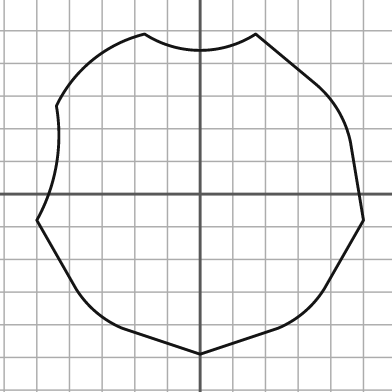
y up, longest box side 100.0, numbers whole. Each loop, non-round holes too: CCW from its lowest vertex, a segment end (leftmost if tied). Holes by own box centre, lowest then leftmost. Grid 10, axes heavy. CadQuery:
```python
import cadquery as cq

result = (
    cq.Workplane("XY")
    .moveTo(0.0, -49.0)
    .lineTo(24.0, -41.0)
    .threePointArc((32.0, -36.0), (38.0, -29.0))
    .lineTo(50.0, -8.0)
    .lineTo(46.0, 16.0)
    .threePointArc((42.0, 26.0), (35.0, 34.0))
    .lineTo(17.0, 49.0)
    .threePointArc((0.0, 44.0), (-17.0, 49.0))
    .threePointArc((-33.0, 41.0), (-44.0, 27.0))
    .threePointArc((-44.0, 9.0), (-50.0, -8.0))
    .lineTo(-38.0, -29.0)
    .threePointArc((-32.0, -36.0), (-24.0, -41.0))
    .close()
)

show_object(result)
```